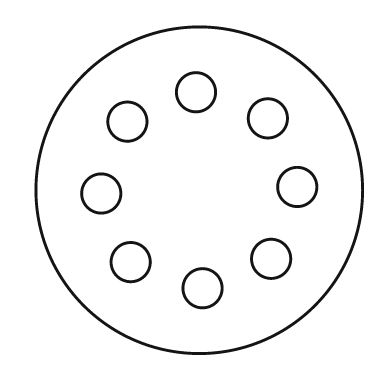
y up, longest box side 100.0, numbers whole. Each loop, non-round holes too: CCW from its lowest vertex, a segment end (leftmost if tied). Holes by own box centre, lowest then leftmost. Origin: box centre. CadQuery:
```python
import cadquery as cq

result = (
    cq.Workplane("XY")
    .moveTo(0.0, 0.0)
    .circle(50.0)
    .moveTo(1.0, -30.0)
    .circle(6.0)
    .moveTo(-21.0, -22.0)
    .circle(6.0)
    .moveTo(22.0, -21.0)
    .circle(6.0)
    .moveTo(-30.0, -1.0)
    .circle(6.0)
    .moveTo(30.0, 1.0)
    .circle(6.0)
    .moveTo(-22.0, 21.0)
    .circle(6.0)
    .moveTo(21.0, 22.0)
    .circle(6.0)
    .moveTo(-1.0, 30.0)
    .circle(6.0)
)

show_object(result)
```